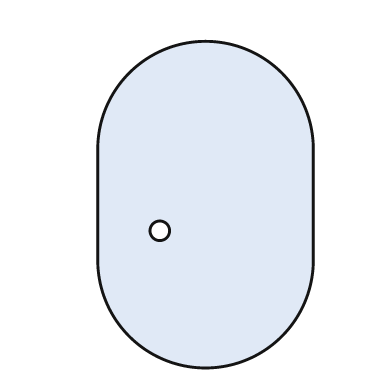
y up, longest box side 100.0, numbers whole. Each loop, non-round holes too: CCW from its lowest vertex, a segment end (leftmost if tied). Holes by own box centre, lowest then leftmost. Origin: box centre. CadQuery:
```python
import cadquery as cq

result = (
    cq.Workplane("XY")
    .moveTo(-33.0, -17.0)
    .threePointArc((0.0, -50.0), (33.0, -17.0))
    .lineTo(33.0, 17.0)
    .threePointArc((0.0, 50.0), (-33.0, 17.0))
    .close()
    .moveTo(-14.0, -8.0)
    .circle(3.0)
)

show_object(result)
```